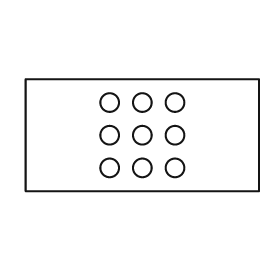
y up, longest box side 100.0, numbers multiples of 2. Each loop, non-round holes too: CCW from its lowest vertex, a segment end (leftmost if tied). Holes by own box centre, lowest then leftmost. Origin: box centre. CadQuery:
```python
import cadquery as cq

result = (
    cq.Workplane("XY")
    .moveTo(-50.0, -24.0)
    .lineTo(50.0, -24.0)
    .lineTo(50.0, 24.0)
    .lineTo(-50.0, 24.0)
    .close()
    .moveTo(-14.0, -14.0)
    .circle(4.0)
    .moveTo(0.0, -14.0)
    .circle(4.0)
    .moveTo(14.0, -14.0)
    .circle(4.0)
    .moveTo(-14.0, 0.0)
    .circle(4.0)
    .moveTo(0.0, 0.0)
    .circle(4.0)
    .moveTo(14.0, 0.0)
    .circle(4.0)
    .moveTo(-14.0, 14.0)
    .circle(4.0)
    .moveTo(0.0, 14.0)
    .circle(4.0)
    .moveTo(14.0, 14.0)
    .circle(4.0)
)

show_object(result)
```